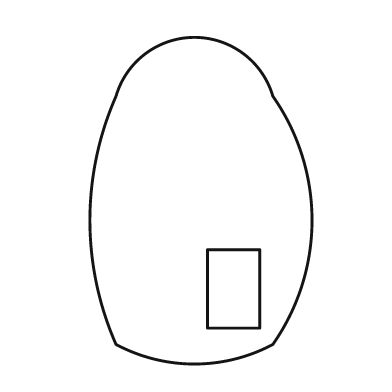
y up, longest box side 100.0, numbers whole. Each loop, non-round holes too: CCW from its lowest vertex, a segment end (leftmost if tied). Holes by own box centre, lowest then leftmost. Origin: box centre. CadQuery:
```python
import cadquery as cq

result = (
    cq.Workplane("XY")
    .moveTo(-26.0, -44.0)
    .threePointArc((-2.0, -50.0), (22.0, -44.0))
    .threePointArc((34.0, -6.0), (22.0, 32.0))
    .threePointArc((-2.0, 50.0), (-26.0, 32.0))
    .threePointArc((-34.0, -6.0), (-26.0, -44.0))
    .close()
    .moveTo(2.0, -39.0)
    .lineTo(18.0, -39.0)
    .lineTo(18.0, -15.0)
    .lineTo(2.0, -15.0)
    .close()
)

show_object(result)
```